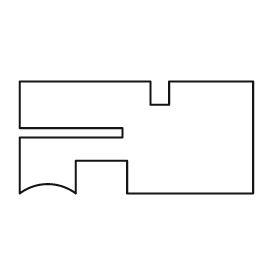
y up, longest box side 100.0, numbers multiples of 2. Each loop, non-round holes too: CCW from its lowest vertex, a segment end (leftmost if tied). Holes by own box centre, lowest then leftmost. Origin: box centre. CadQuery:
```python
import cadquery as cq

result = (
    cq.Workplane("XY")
    .moveTo(-50.0, -24.0)
    .threePointArc((-38.0, -20.0), (-26.0, -24.0))
    .lineTo(-26.0, -10.0)
    .lineTo(-4.0, -10.0)
    .lineTo(-4.0, -24.0)
    .lineTo(50.0, -24.0)
    .lineTo(50.0, 24.0)
    .lineTo(14.0, 24.0)
    .lineTo(14.0, 14.0)
    .lineTo(6.0, 14.0)
    .lineTo(6.0, 24.0)
    .lineTo(-50.0, 24.0)
    .lineTo(-50.0, 4.0)
    .lineTo(-6.0, 4.0)
    .lineTo(-6.0, 0.0)
    .lineTo(-50.0, 0.0)
    .close()
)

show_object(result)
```